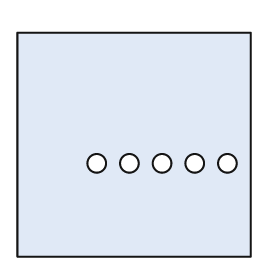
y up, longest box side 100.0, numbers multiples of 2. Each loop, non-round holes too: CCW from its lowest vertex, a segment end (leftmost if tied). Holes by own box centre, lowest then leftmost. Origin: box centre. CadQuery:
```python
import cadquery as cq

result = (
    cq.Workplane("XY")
    .moveTo(-50.0, -48.0)
    .lineTo(50.0, -48.0)
    .lineTo(50.0, 48.0)
    .lineTo(-50.0, 48.0)
    .close()
    .moveTo(-16.0, -8.0)
    .circle(4.0)
    .moveTo(-2.0, -8.0)
    .circle(4.0)
    .moveTo(12.0, -8.0)
    .circle(4.0)
    .moveTo(26.0, -8.0)
    .circle(4.0)
    .moveTo(40.0, -8.0)
    .circle(4.0)
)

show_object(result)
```